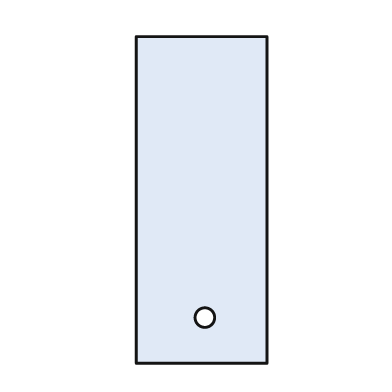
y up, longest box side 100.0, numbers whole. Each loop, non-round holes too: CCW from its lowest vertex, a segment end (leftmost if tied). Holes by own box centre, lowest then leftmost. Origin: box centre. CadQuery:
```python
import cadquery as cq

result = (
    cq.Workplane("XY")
    .moveTo(-20.0, -50.0)
    .lineTo(20.0, -50.0)
    .lineTo(20.0, 50.0)
    .lineTo(-20.0, 50.0)
    .close()
    .moveTo(1.0, -36.0)
    .circle(3.0)
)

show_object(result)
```